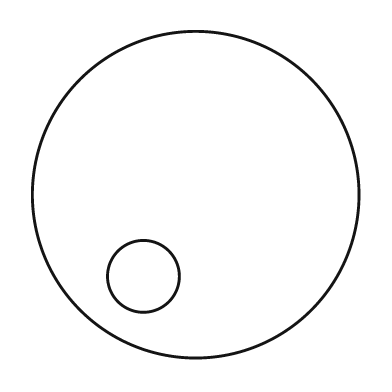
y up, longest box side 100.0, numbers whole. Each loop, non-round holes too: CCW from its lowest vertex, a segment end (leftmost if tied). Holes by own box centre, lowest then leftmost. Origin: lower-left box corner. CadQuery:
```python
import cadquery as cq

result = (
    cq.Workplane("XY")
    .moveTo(50.0, 50.0)
    .circle(50.0)
    .moveTo(34.0, 25.0)
    .circle(11.0)
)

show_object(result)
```